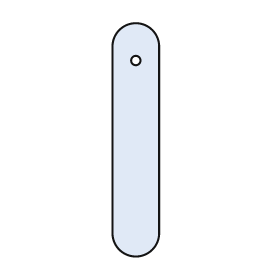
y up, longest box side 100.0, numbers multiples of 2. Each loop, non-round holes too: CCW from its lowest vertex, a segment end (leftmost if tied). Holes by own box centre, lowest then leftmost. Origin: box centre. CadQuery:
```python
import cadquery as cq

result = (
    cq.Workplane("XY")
    .moveTo(-10.0, -40.0)
    .threePointArc((0.0, -50.0), (10.0, -40.0))
    .lineTo(10.0, 40.0)
    .threePointArc((0.0, 50.0), (-10.0, 40.0))
    .close()
    .moveTo(0.0, 34.0)
    .circle(2.0)
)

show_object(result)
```